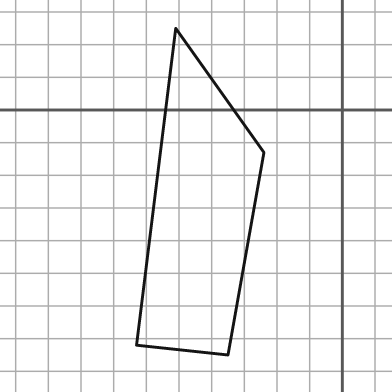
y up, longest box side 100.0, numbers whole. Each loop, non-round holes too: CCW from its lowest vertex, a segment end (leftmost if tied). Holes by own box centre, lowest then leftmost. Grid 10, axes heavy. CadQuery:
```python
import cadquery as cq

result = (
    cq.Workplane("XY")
    .moveTo(-35.0, -75.0)
    .lineTo(-24.0, -13.0)
    .lineTo(-51.0, 25.0)
    .lineTo(-63.0, -72.0)
    .close()
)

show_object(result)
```